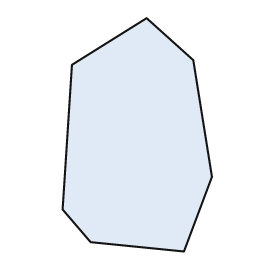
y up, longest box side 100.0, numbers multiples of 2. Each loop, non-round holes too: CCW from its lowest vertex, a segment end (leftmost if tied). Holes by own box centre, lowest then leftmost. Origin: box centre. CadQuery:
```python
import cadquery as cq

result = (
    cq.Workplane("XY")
    .moveTo(20.0, -50.0)
    .lineTo(32.0, -18.0)
    .lineTo(24.0, 32.0)
    .lineTo(4.0, 50.0)
    .lineTo(-28.0, 30.0)
    .lineTo(-32.0, -32.0)
    .lineTo(-20.0, -46.0)
    .close()
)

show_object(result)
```